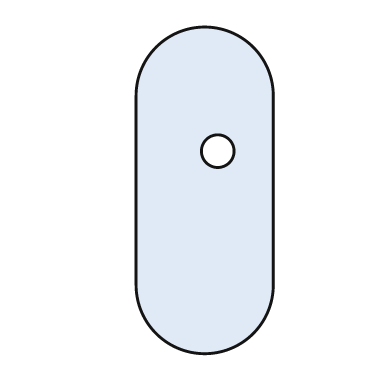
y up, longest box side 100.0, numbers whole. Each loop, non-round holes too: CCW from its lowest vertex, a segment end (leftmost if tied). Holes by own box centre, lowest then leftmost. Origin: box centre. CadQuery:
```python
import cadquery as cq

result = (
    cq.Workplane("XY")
    .moveTo(-21.0, -29.0)
    .threePointArc((0.0, -50.0), (21.0, -29.0))
    .lineTo(21.0, 29.0)
    .threePointArc((0.0, 50.0), (-21.0, 29.0))
    .close()
    .moveTo(4.0, 12.0)
    .circle(5.0)
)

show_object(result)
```